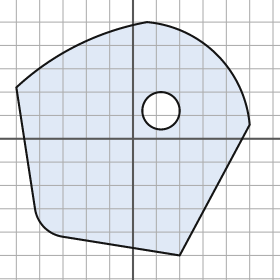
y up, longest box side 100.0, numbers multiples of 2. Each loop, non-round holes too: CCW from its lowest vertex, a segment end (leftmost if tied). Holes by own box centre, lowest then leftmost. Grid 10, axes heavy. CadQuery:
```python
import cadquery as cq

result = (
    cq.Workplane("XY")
    .moveTo(20.0, -50.0)
    .lineTo(50.0, 6.0)
    .threePointArc((36.0, 36.0), (6.0, 50.0))
    .threePointArc((-24.0, 40.0), (-50.0, 22.0))
    .lineTo(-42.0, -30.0)
    .threePointArc((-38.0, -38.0), (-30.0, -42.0))
    .close()
    .moveTo(12.0, 12.0)
    .circle(8.0)
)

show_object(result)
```